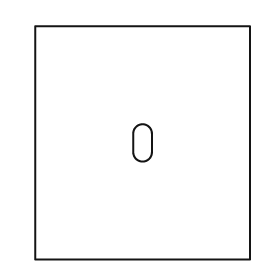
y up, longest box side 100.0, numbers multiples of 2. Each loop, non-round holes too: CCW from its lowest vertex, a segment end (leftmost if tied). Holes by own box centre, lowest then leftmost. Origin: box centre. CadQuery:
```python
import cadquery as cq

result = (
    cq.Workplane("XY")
    .moveTo(-46.0, -50.0)
    .lineTo(46.0, -50.0)
    .lineTo(46.0, 50.0)
    .lineTo(-46.0, 50.0)
    .close()
    .moveTo(-4.0, -4.0)
    .threePointArc((0.0, -8.0), (4.0, -4.0))
    .lineTo(4.0, 4.0)
    .threePointArc((0.0, 8.0), (-4.0, 4.0))
    .close()
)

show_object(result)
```